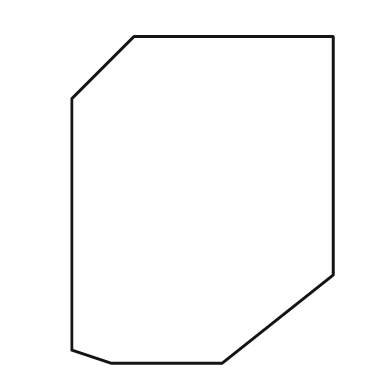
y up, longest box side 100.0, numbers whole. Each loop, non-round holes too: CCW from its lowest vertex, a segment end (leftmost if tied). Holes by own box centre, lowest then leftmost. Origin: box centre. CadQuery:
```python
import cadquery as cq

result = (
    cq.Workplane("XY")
    .moveTo(-28.0, -50.0)
    .lineTo(6.0, -50.0)
    .lineTo(40.0, -23.0)
    .lineTo(40.0, 50.0)
    .lineTo(-21.0, 50.0)
    .lineTo(-40.0, 31.0)
    .lineTo(-40.0, -46.0)
    .close()
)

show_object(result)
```